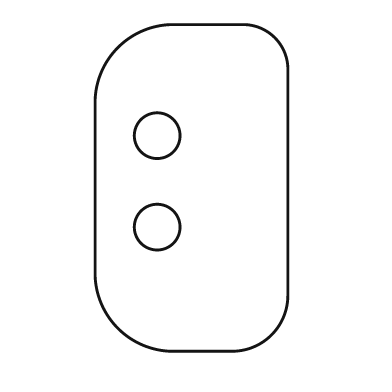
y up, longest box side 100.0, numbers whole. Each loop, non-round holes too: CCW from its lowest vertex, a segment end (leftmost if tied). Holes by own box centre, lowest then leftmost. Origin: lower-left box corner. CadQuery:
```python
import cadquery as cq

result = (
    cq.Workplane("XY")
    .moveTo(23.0, 0.0)
    .lineTo(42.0, 0.0)
    .threePointArc((54.0, 5.0), (59.0, 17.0))
    .lineTo(59.0, 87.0)
    .threePointArc((55.0, 96.0), (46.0, 100.0))
    .lineTo(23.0, 100.0)
    .threePointArc((7.0, 93.0), (0.0, 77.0))
    .lineTo(0.0, 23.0)
    .threePointArc((7.0, 7.0), (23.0, 0.0))
    .close()
    .moveTo(19.0, 38.0)
    .circle(7.0)
    .moveTo(19.0, 66.0)
    .circle(7.0)
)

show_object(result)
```